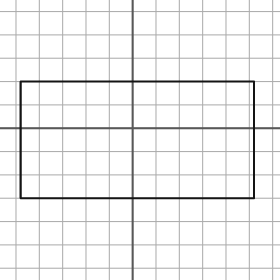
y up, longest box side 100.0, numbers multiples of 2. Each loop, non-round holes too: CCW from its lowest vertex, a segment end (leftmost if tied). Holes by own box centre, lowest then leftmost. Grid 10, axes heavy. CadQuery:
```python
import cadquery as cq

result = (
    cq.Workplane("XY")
    .moveTo(-48.0, -30.0)
    .lineTo(52.0, -30.0)
    .lineTo(52.0, 20.0)
    .lineTo(-48.0, 20.0)
    .close()
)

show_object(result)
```